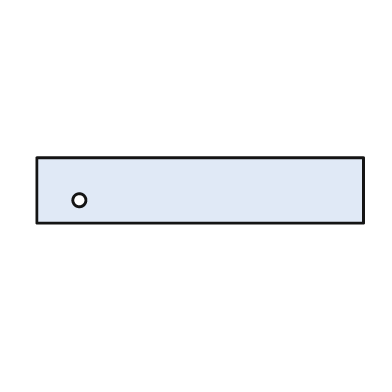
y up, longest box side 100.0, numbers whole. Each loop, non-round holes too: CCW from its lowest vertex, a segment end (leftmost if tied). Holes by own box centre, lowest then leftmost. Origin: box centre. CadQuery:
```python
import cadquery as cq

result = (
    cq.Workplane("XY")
    .moveTo(-50.0, -10.0)
    .lineTo(50.0, -10.0)
    .lineTo(50.0, 10.0)
    .lineTo(-50.0, 10.0)
    .close()
    .moveTo(-37.0, -3.0)
    .circle(2.0)
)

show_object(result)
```